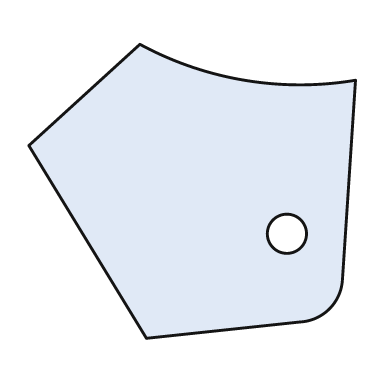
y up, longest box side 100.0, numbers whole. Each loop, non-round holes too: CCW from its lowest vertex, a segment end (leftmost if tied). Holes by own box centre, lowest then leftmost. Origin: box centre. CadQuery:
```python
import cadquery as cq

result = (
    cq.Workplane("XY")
    .moveTo(-14.0, -45.0)
    .lineTo(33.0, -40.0)
    .threePointArc((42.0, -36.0), (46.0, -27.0))
    .lineTo(50.0, 34.0)
    .threePointArc((16.0, 34.0), (-16.0, 45.0))
    .lineTo(-50.0, 14.0)
    .close()
    .moveTo(29.0, -13.0)
    .circle(6.0)
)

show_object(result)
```